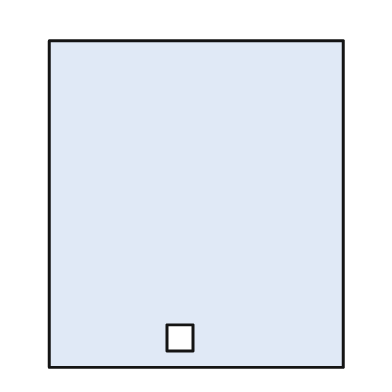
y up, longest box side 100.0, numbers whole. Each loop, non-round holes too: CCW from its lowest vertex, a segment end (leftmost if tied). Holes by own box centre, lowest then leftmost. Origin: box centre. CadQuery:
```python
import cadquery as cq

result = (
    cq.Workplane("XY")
    .moveTo(-45.0, -50.0)
    .lineTo(45.0, -50.0)
    .lineTo(45.0, 50.0)
    .lineTo(-45.0, 50.0)
    .close()
    .moveTo(-9.0, -45.0)
    .lineTo(-1.0, -45.0)
    .lineTo(-1.0, -37.0)
    .lineTo(-9.0, -37.0)
    .close()
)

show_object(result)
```